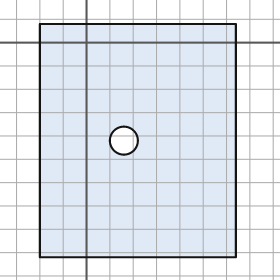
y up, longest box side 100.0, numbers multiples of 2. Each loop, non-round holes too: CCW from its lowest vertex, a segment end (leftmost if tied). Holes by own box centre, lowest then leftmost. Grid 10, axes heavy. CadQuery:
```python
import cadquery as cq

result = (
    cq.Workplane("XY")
    .moveTo(-20.0, -92.0)
    .lineTo(64.0, -92.0)
    .lineTo(64.0, 8.0)
    .lineTo(-20.0, 8.0)
    .close()
    .moveTo(16.0, -42.0)
    .circle(6.0)
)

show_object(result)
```